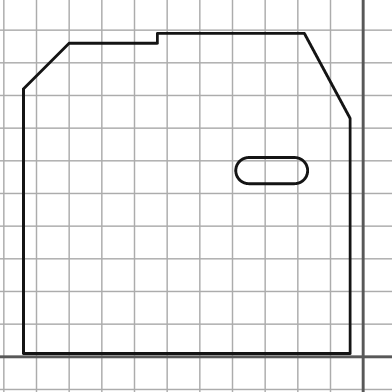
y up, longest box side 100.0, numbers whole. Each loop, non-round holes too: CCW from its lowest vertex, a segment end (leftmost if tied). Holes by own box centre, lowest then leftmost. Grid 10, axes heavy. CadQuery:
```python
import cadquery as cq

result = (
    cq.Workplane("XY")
    .moveTo(-104.0, 1.0)
    .lineTo(-4.0, 1.0)
    .lineTo(-4.0, 73.0)
    .lineTo(-18.0, 99.0)
    .lineTo(-63.0, 99.0)
    .lineTo(-63.0, 96.0)
    .lineTo(-90.0, 96.0)
    .lineTo(-104.0, 82.0)
    .close()
    .moveTo(-35.0, 53.0)
    .lineTo(-21.0, 53.0)
    .threePointArc((-17.0, 57.0), (-21.0, 61.0))
    .lineTo(-35.0, 61.0)
    .threePointArc((-39.0, 57.0), (-35.0, 53.0))
    .close()
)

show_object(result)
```